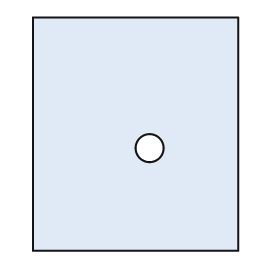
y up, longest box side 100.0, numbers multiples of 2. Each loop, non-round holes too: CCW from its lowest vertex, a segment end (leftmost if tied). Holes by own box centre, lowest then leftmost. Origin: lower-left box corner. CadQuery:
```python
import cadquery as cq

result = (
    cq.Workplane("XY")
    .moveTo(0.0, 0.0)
    .lineTo(88.0, 0.0)
    .lineTo(88.0, 100.0)
    .lineTo(0.0, 100.0)
    .close()
    .moveTo(50.0, 44.0)
    .circle(6.0)
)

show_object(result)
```